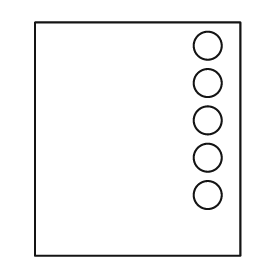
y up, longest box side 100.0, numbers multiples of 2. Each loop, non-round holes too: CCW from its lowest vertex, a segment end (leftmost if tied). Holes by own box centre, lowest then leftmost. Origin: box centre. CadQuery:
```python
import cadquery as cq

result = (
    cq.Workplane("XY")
    .moveTo(-44.0, -50.0)
    .lineTo(44.0, -50.0)
    .lineTo(44.0, 50.0)
    .lineTo(-44.0, 50.0)
    .close()
    .moveTo(30.0, -24.0)
    .circle(6.0)
    .moveTo(30.0, -8.0)
    .circle(6.0)
    .moveTo(30.0, 8.0)
    .circle(6.0)
    .moveTo(30.0, 24.0)
    .circle(6.0)
    .moveTo(30.0, 40.0)
    .circle(6.0)
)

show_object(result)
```